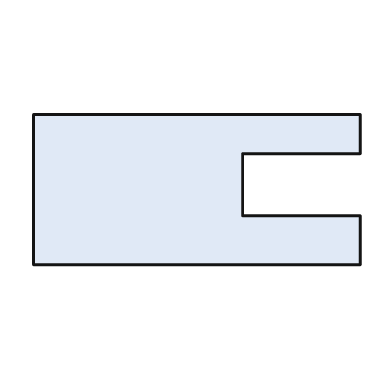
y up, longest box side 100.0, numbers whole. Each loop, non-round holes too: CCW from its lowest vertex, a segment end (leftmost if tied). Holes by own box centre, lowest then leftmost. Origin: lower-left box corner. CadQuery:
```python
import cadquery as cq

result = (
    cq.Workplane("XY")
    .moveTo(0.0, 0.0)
    .lineTo(100.0, 0.0)
    .lineTo(100.0, 15.0)
    .lineTo(64.0, 15.0)
    .lineTo(64.0, 34.0)
    .lineTo(100.0, 34.0)
    .lineTo(100.0, 46.0)
    .lineTo(0.0, 46.0)
    .close()
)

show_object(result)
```